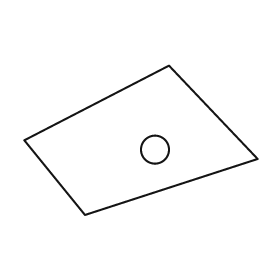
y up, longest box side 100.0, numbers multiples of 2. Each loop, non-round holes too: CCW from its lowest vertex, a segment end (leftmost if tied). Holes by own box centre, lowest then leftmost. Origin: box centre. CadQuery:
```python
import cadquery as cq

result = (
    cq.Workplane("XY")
    .moveTo(-24.0, -32.0)
    .lineTo(50.0, -8.0)
    .lineTo(12.0, 32.0)
    .lineTo(-50.0, 0.0)
    .close()
    .moveTo(6.0, -4.0)
    .circle(6.0)
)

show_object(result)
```